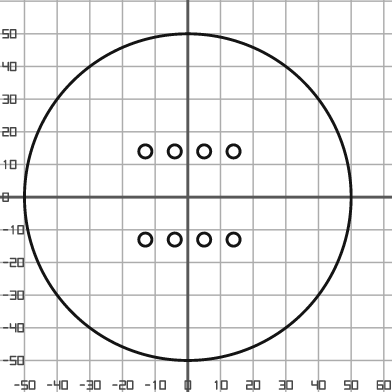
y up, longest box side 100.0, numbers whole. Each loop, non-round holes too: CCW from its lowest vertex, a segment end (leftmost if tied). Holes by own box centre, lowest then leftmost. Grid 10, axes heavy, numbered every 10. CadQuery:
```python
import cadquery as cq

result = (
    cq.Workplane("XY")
    .moveTo(0.0, 0.0)
    .circle(50.0)
    .moveTo(-13.0, -13.0)
    .circle(2.0)
    .moveTo(-4.0, -13.0)
    .circle(2.0)
    .moveTo(5.0, -13.0)
    .circle(2.0)
    .moveTo(14.0, -13.0)
    .circle(2.0)
    .moveTo(-13.0, 14.0)
    .circle(2.0)
    .moveTo(-4.0, 14.0)
    .circle(2.0)
    .moveTo(5.0, 14.0)
    .circle(2.0)
    .moveTo(14.0, 14.0)
    .circle(2.0)
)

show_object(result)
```